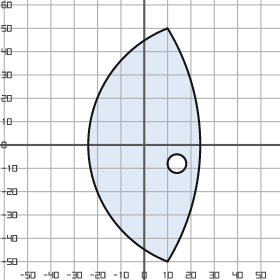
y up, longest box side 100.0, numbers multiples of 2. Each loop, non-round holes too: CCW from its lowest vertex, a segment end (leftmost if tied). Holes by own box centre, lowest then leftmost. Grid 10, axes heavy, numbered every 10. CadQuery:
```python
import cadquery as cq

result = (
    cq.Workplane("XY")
    .moveTo(10.0, -50.0)
    .threePointArc((24.0, 0.0), (10.0, 50.0))
    .threePointArc((-24.0, 0.0), (10.0, -50.0))
    .close()
    .moveTo(14.0, -8.0)
    .circle(4.0)
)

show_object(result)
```